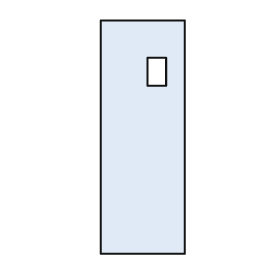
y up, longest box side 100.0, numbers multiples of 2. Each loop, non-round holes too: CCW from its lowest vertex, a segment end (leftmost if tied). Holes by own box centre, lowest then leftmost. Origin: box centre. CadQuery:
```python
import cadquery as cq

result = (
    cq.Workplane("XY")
    .moveTo(-18.0, -50.0)
    .lineTo(18.0, -50.0)
    .lineTo(18.0, 50.0)
    .lineTo(-18.0, 50.0)
    .close()
    .moveTo(2.0, 22.0)
    .lineTo(10.0, 22.0)
    .lineTo(10.0, 34.0)
    .lineTo(2.0, 34.0)
    .close()
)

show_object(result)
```